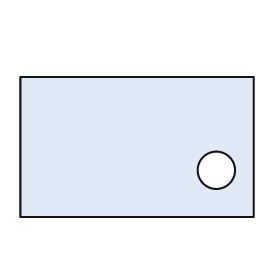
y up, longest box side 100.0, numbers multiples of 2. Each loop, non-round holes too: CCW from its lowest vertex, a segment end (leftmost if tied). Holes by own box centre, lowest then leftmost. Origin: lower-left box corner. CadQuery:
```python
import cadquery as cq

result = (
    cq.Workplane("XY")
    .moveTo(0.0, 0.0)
    .lineTo(100.0, 0.0)
    .lineTo(100.0, 60.0)
    .lineTo(0.0, 60.0)
    .close()
    .moveTo(84.0, 20.0)
    .circle(8.0)
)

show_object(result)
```